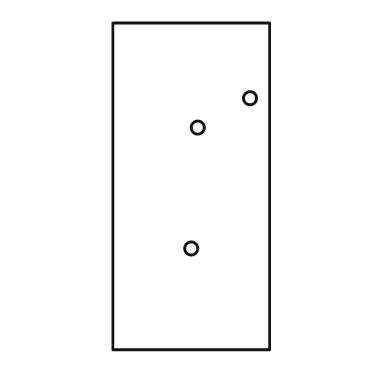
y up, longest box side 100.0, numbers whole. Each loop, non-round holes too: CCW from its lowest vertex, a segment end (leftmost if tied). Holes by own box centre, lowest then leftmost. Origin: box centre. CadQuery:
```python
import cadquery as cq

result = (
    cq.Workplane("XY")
    .moveTo(-24.0, -50.0)
    .lineTo(24.0, -50.0)
    .lineTo(24.0, 50.0)
    .lineTo(-24.0, 50.0)
    .close()
    .moveTo(0.0, -19.0)
    .circle(2.0)
    .moveTo(2.0, 18.0)
    .circle(2.0)
    .moveTo(18.0, 27.0)
    .circle(2.0)
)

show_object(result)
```